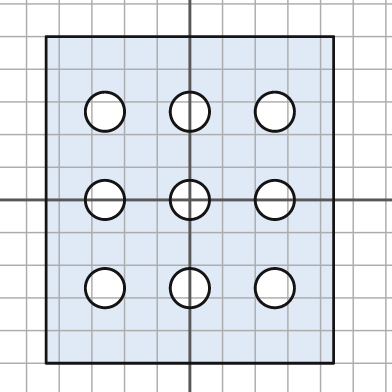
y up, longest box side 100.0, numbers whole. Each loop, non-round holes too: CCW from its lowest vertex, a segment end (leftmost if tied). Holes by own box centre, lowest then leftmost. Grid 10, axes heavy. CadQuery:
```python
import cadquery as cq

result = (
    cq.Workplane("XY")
    .moveTo(-44.0, -50.0)
    .lineTo(44.0, -50.0)
    .lineTo(44.0, 50.0)
    .lineTo(-44.0, 50.0)
    .close()
    .moveTo(-26.0, -27.0)
    .circle(6.0)
    .moveTo(0.0, -27.0)
    .circle(6.0)
    .moveTo(26.0, -27.0)
    .circle(6.0)
    .moveTo(-26.0, 0.0)
    .circle(6.0)
    .moveTo(0.0, 0.0)
    .circle(6.0)
    .moveTo(26.0, 0.0)
    .circle(6.0)
    .moveTo(-26.0, 27.0)
    .circle(6.0)
    .moveTo(0.0, 27.0)
    .circle(6.0)
    .moveTo(26.0, 27.0)
    .circle(6.0)
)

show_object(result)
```